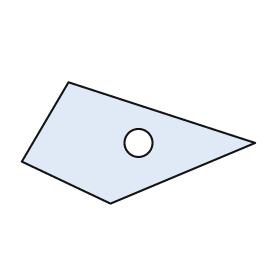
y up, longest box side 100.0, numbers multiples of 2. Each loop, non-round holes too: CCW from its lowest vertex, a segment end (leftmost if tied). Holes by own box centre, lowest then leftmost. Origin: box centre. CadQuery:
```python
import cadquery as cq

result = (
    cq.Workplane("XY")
    .moveTo(-12.0, -26.0)
    .lineTo(50.0, 0.0)
    .lineTo(-30.0, 26.0)
    .lineTo(-50.0, -8.0)
    .close()
    .moveTo(0.0, 0.0)
    .circle(6.0)
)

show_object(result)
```